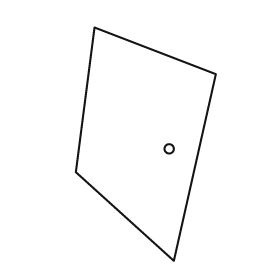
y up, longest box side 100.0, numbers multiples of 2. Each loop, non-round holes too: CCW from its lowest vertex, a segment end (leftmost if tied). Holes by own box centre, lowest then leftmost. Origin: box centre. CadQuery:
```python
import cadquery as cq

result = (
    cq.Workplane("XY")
    .moveTo(12.0, -50.0)
    .lineTo(30.0, 30.0)
    .lineTo(-22.0, 50.0)
    .lineTo(-30.0, -12.0)
    .close()
    .moveTo(10.0, -2.0)
    .circle(2.0)
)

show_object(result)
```